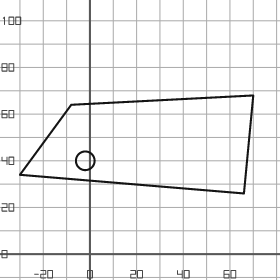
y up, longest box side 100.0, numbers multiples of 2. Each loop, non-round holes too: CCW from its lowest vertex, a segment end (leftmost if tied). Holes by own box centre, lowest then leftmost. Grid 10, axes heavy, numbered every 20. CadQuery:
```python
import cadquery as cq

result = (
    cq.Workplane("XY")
    .moveTo(66.0, 26.0)
    .lineTo(70.0, 68.0)
    .lineTo(-8.0, 64.0)
    .lineTo(-30.0, 34.0)
    .close()
    .moveTo(-2.0, 40.0)
    .circle(4.0)
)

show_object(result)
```